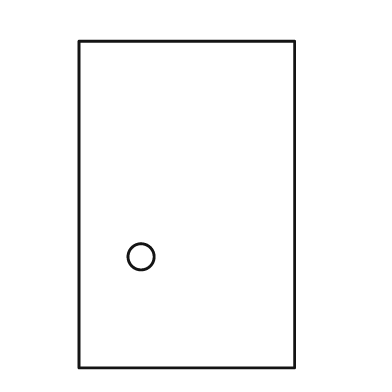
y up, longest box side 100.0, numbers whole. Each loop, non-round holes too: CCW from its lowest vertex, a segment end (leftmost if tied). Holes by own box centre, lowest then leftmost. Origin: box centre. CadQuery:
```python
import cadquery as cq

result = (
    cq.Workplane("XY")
    .moveTo(-33.0, -50.0)
    .lineTo(33.0, -50.0)
    .lineTo(33.0, 50.0)
    .lineTo(-33.0, 50.0)
    .close()
    .moveTo(-14.0, -16.0)
    .circle(4.0)
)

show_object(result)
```